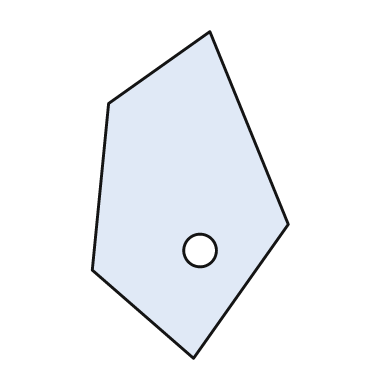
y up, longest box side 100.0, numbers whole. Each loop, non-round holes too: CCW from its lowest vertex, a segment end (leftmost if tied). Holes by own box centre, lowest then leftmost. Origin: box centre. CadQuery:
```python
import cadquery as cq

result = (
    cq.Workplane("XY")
    .moveTo(1.0, -50.0)
    .lineTo(30.0, -9.0)
    .lineTo(6.0, 50.0)
    .lineTo(-25.0, 28.0)
    .lineTo(-30.0, -23.0)
    .close()
    .moveTo(3.0, -17.0)
    .circle(5.0)
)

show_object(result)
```